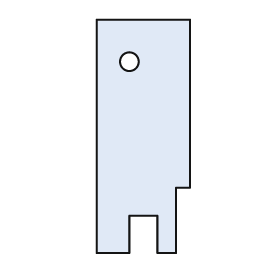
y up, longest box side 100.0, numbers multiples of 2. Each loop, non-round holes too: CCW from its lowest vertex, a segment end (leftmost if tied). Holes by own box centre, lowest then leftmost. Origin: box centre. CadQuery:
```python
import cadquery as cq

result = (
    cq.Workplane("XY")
    .moveTo(-20.0, -50.0)
    .lineTo(-6.0, -50.0)
    .lineTo(-6.0, -34.0)
    .lineTo(6.0, -34.0)
    .lineTo(6.0, -50.0)
    .lineTo(14.0, -50.0)
    .lineTo(14.0, -22.0)
    .lineTo(20.0, -22.0)
    .lineTo(20.0, 50.0)
    .lineTo(-20.0, 50.0)
    .close()
    .moveTo(-6.0, 32.0)
    .circle(4.0)
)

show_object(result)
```